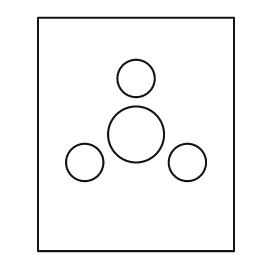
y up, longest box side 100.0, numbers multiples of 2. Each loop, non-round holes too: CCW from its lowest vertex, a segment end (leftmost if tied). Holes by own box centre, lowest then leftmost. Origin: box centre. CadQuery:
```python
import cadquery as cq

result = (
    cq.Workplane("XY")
    .moveTo(-42.0, -50.0)
    .lineTo(42.0, -50.0)
    .lineTo(42.0, 50.0)
    .lineTo(-42.0, 50.0)
    .close()
    .moveTo(-22.0, -12.0)
    .circle(8.0)
    .moveTo(22.0, -12.0)
    .circle(8.0)
    .moveTo(0.0, 0.0)
    .circle(12.0)
    .moveTo(0.0, 24.0)
    .circle(8.0)
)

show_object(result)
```